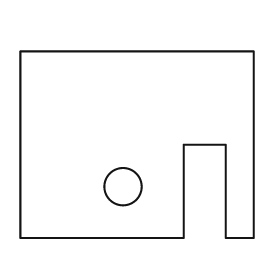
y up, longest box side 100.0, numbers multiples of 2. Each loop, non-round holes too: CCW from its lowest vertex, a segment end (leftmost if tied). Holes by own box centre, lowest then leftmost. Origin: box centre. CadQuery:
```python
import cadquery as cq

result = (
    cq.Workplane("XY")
    .moveTo(-50.0, -40.0)
    .lineTo(20.0, -40.0)
    .lineTo(20.0, 0.0)
    .lineTo(38.0, 0.0)
    .lineTo(38.0, -40.0)
    .lineTo(50.0, -40.0)
    .lineTo(50.0, 40.0)
    .lineTo(-50.0, 40.0)
    .close()
    .moveTo(-6.0, -18.0)
    .circle(8.0)
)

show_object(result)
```